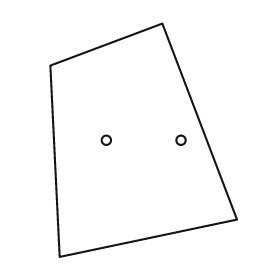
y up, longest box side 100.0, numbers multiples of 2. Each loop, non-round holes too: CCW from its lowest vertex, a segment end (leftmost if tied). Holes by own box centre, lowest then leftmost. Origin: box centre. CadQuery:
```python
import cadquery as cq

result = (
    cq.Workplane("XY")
    .moveTo(-36.0, -50.0)
    .lineTo(40.0, -34.0)
    .lineTo(8.0, 50.0)
    .lineTo(-40.0, 32.0)
    .close()
    .moveTo(-16.0, 0.0)
    .circle(2.0)
    .moveTo(16.0, 0.0)
    .circle(2.0)
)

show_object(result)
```